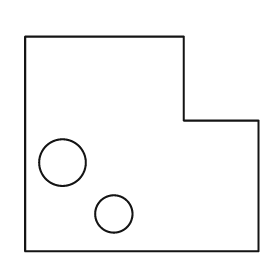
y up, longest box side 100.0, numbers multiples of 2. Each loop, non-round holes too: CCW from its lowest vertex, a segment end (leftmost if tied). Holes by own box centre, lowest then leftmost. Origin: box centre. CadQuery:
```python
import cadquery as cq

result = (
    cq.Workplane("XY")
    .moveTo(-50.0, -46.0)
    .lineTo(50.0, -46.0)
    .lineTo(50.0, 10.0)
    .lineTo(18.0, 10.0)
    .lineTo(18.0, 46.0)
    .lineTo(-50.0, 46.0)
    .close()
    .moveTo(-12.0, -30.0)
    .circle(8.0)
    .moveTo(-34.0, -8.0)
    .circle(10.0)
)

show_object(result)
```